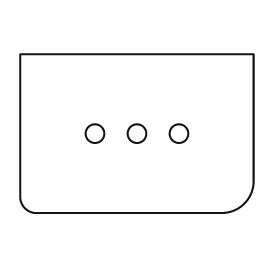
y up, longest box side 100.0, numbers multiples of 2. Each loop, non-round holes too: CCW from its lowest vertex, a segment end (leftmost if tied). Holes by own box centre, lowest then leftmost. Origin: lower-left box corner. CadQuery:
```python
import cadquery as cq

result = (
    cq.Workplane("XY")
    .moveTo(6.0, 0.0)
    .lineTo(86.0, 0.0)
    .threePointArc((96.0, 4.0), (100.0, 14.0))
    .lineTo(100.0, 68.0)
    .lineTo(0.0, 68.0)
    .lineTo(0.0, 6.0)
    .threePointArc((2.0, 2.0), (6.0, 0.0))
    .close()
    .moveTo(32.0, 34.0)
    .circle(4.0)
    .moveTo(50.0, 34.0)
    .circle(4.0)
    .moveTo(68.0, 34.0)
    .circle(4.0)
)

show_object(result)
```